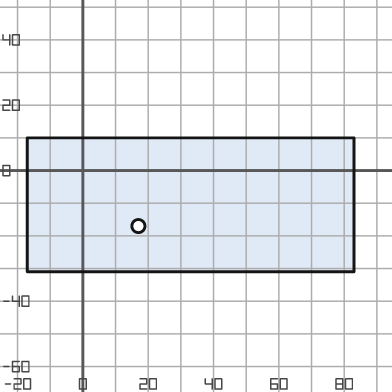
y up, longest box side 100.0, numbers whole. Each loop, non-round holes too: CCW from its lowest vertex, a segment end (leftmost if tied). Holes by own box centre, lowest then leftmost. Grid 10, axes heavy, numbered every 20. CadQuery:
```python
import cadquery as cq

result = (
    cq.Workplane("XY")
    .moveTo(-17.0, -31.0)
    .lineTo(83.0, -31.0)
    .lineTo(83.0, 10.0)
    .lineTo(-17.0, 10.0)
    .close()
    .moveTo(17.0, -17.0)
    .circle(2.0)
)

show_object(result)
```